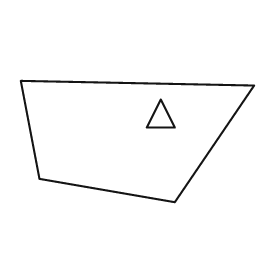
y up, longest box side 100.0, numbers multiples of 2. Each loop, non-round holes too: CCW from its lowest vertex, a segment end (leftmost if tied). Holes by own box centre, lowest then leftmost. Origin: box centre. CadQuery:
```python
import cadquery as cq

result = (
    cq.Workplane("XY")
    .moveTo(16.0, -26.0)
    .lineTo(50.0, 24.0)
    .lineTo(-50.0, 26.0)
    .lineTo(-42.0, -16.0)
    .close()
    .moveTo(4.0, 6.0)
    .lineTo(16.0, 6.0)
    .lineTo(10.0, 18.0)
    .close()
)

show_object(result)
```